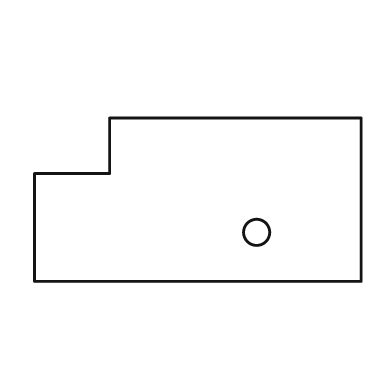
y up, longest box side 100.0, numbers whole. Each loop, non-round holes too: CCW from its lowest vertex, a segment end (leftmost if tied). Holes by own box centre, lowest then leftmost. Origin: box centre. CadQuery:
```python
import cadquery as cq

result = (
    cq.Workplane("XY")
    .moveTo(-50.0, -25.0)
    .lineTo(50.0, -25.0)
    .lineTo(50.0, 25.0)
    .lineTo(-27.0, 25.0)
    .lineTo(-27.0, 8.0)
    .lineTo(-50.0, 8.0)
    .close()
    .moveTo(18.0, -10.0)
    .circle(4.0)
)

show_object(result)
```